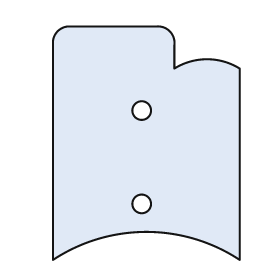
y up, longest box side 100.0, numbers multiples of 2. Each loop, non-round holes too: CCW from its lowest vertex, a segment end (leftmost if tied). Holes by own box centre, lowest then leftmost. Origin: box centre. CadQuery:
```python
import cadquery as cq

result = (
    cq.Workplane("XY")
    .moveTo(-40.0, -50.0)
    .threePointArc((0.0, -38.0), (40.0, -50.0))
    .lineTo(40.0, 32.0)
    .threePointArc((26.0, 36.0), (12.0, 32.0))
    .lineTo(12.0, 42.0)
    .threePointArc((10.0, 48.0), (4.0, 50.0))
    .lineTo(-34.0, 50.0)
    .threePointArc((-38.0, 48.0), (-40.0, 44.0))
    .close()
    .moveTo(-2.0, -26.0)
    .circle(4.0)
    .moveTo(-2.0, 14.0)
    .circle(4.0)
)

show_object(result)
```